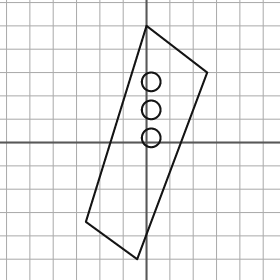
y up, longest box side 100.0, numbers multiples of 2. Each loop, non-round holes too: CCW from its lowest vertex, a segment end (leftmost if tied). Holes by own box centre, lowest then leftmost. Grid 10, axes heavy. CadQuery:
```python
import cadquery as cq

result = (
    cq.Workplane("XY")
    .moveTo(-4.0, -50.0)
    .lineTo(26.0, 30.0)
    .lineTo(0.0, 50.0)
    .lineTo(-26.0, -34.0)
    .close()
    .moveTo(2.0, 2.0)
    .circle(4.0)
    .moveTo(2.0, 14.0)
    .circle(4.0)
    .moveTo(2.0, 26.0)
    .circle(4.0)
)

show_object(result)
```